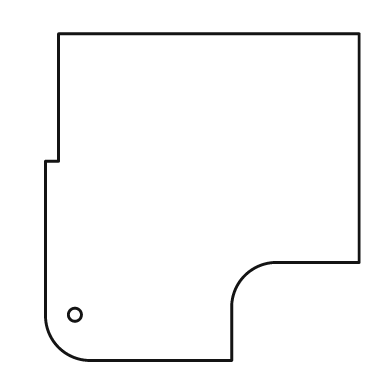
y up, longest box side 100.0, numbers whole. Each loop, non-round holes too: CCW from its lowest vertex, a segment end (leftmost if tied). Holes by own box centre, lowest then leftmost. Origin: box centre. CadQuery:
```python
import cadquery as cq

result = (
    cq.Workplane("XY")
    .moveTo(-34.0, -50.0)
    .lineTo(9.0, -50.0)
    .lineTo(9.0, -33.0)
    .threePointArc((13.0, -24.0), (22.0, -20.0))
    .lineTo(48.0, -20.0)
    .lineTo(48.0, 50.0)
    .lineTo(-44.0, 50.0)
    .lineTo(-44.0, 11.0)
    .lineTo(-48.0, 11.0)
    .lineTo(-48.0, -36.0)
    .threePointArc((-44.0, -46.0), (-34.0, -50.0))
    .close()
    .moveTo(-39.0, -36.0)
    .circle(2.0)
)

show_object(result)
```